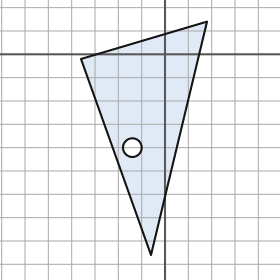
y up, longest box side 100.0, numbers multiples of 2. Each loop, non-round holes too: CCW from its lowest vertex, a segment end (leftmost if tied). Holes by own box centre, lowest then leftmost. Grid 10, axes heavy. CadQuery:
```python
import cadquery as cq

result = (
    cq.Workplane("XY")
    .moveTo(-6.0, -86.0)
    .lineTo(18.0, 14.0)
    .lineTo(-36.0, -2.0)
    .close()
    .moveTo(-14.0, -40.0)
    .circle(4.0)
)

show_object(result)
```